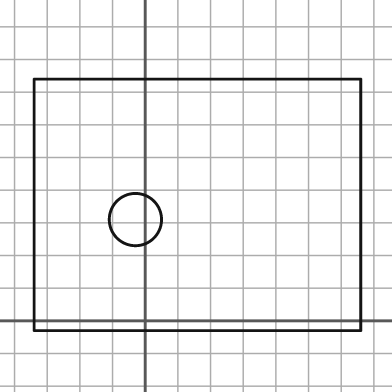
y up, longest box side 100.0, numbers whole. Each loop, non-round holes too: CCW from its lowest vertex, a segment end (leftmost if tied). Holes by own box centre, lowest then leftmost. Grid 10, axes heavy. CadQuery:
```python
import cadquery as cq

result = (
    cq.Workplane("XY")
    .moveTo(-34.0, -3.0)
    .lineTo(66.0, -3.0)
    .lineTo(66.0, 74.0)
    .lineTo(-34.0, 74.0)
    .close()
    .moveTo(-3.0, 31.0)
    .circle(8.0)
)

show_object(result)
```